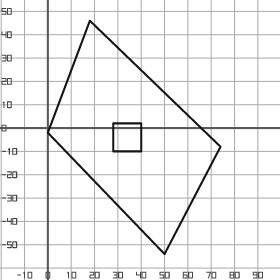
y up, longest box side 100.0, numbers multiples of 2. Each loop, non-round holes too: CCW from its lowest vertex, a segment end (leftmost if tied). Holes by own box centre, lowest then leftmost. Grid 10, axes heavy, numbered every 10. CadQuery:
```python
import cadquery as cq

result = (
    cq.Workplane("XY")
    .moveTo(50.0, -54.0)
    .lineTo(74.0, -8.0)
    .lineTo(18.0, 46.0)
    .lineTo(0.0, -2.0)
    .close()
    .moveTo(28.0, -10.0)
    .lineTo(40.0, -10.0)
    .lineTo(40.0, 2.0)
    .lineTo(28.0, 2.0)
    .close()
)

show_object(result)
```